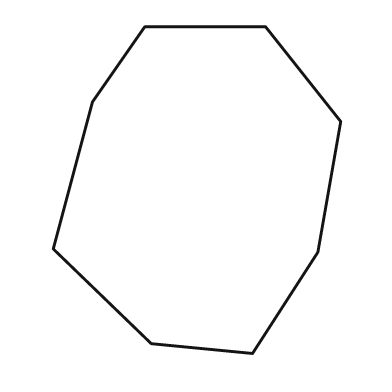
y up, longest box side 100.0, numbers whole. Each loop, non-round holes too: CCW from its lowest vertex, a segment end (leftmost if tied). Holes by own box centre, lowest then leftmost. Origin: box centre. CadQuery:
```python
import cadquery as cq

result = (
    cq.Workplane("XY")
    .moveTo(17.0, -50.0)
    .lineTo(37.0, -19.0)
    .lineTo(44.0, 21.0)
    .lineTo(21.0, 50.0)
    .lineTo(-16.0, 50.0)
    .lineTo(-32.0, 27.0)
    .lineTo(-44.0, -18.0)
    .lineTo(-14.0, -47.0)
    .close()
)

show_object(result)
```